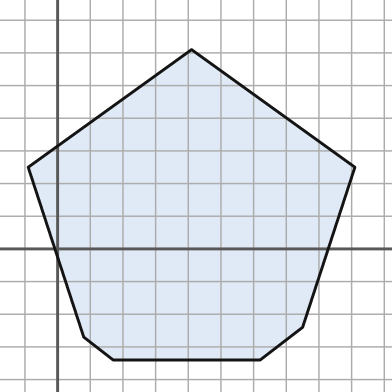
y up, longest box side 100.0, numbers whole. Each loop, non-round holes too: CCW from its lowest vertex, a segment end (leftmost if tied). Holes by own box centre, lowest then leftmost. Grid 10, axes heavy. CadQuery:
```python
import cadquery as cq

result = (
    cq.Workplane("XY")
    .moveTo(17.0, -34.0)
    .lineTo(62.0, -34.0)
    .lineTo(75.0, -24.0)
    .lineTo(91.0, 25.0)
    .lineTo(41.0, 61.0)
    .lineTo(-9.0, 25.0)
    .lineTo(8.0, -27.0)
    .close()
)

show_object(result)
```